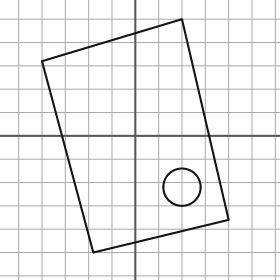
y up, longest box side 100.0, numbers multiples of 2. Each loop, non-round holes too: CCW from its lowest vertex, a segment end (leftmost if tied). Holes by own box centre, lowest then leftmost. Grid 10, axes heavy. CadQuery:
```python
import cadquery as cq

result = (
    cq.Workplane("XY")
    .moveTo(-18.0, -50.0)
    .lineTo(40.0, -36.0)
    .lineTo(20.0, 50.0)
    .lineTo(-40.0, 32.0)
    .close()
    .moveTo(20.0, -22.0)
    .circle(8.0)
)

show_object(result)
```